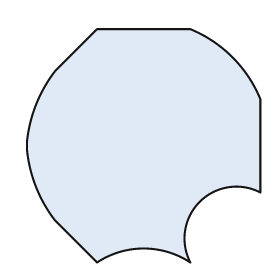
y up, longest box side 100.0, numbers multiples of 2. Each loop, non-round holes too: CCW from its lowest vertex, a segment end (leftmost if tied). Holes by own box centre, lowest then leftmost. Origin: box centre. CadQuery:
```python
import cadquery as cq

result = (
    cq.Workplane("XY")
    .moveTo(-20.0, -50.0)
    .threePointArc((0.0, -44.0), (20.0, -50.0))
    .threePointArc((24.0, -24.0), (50.0, -20.0))
    .lineTo(50.0, 20.0)
    .threePointArc((38.0, 38.0), (20.0, 50.0))
    .lineTo(-20.0, 50.0)
    .lineTo(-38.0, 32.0)
    .threePointArc((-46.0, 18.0), (-50.0, 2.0))
    .lineTo(-50.0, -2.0)
    .threePointArc((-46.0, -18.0), (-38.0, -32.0))
    .close()
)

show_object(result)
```